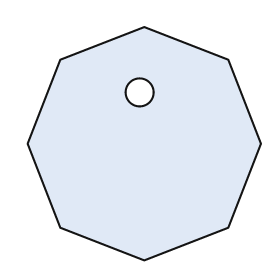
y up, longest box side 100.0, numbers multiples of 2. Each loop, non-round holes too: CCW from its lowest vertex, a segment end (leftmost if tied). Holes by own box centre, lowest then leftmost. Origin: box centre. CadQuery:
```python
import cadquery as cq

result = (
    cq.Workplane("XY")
    .moveTo(0.0, -50.0)
    .lineTo(36.0, -36.0)
    .lineTo(50.0, 0.0)
    .lineTo(36.0, 36.0)
    .lineTo(0.0, 50.0)
    .lineTo(-36.0, 36.0)
    .lineTo(-50.0, 0.0)
    .lineTo(-36.0, -36.0)
    .close()
    .moveTo(-2.0, 22.0)
    .circle(6.0)
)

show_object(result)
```